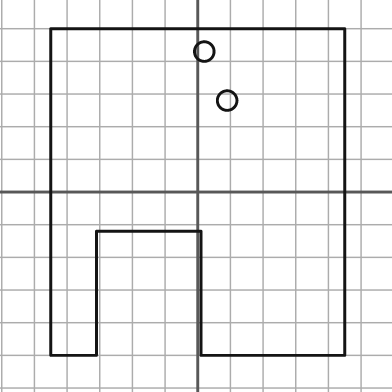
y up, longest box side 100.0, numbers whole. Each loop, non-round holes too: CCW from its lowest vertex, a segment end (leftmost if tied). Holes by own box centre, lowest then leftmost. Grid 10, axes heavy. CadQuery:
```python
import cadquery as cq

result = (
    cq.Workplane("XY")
    .moveTo(-45.0, -50.0)
    .lineTo(-31.0, -50.0)
    .lineTo(-31.0, -12.0)
    .lineTo(1.0, -12.0)
    .lineTo(1.0, -50.0)
    .lineTo(45.0, -50.0)
    .lineTo(45.0, 50.0)
    .lineTo(-45.0, 50.0)
    .close()
    .moveTo(9.0, 28.0)
    .circle(3.0)
    .moveTo(2.0, 43.0)
    .circle(3.0)
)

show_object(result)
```